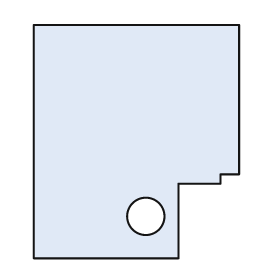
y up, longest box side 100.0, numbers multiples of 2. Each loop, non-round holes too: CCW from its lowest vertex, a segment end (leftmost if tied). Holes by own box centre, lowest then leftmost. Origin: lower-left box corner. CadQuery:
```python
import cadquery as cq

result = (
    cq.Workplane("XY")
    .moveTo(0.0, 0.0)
    .lineTo(62.0, 0.0)
    .lineTo(62.0, 32.0)
    .lineTo(80.0, 32.0)
    .lineTo(80.0, 36.0)
    .lineTo(88.0, 36.0)
    .lineTo(88.0, 100.0)
    .lineTo(0.0, 100.0)
    .close()
    .moveTo(48.0, 18.0)
    .circle(8.0)
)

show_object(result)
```